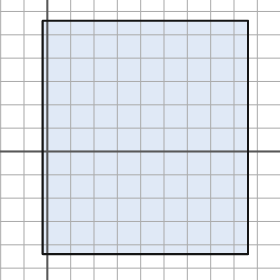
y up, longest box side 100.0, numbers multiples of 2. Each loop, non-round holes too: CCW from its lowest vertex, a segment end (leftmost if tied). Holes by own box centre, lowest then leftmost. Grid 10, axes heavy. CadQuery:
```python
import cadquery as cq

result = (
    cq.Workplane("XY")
    .moveTo(-2.0, -44.0)
    .lineTo(86.0, -44.0)
    .lineTo(86.0, 56.0)
    .lineTo(-2.0, 56.0)
    .close()
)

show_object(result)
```